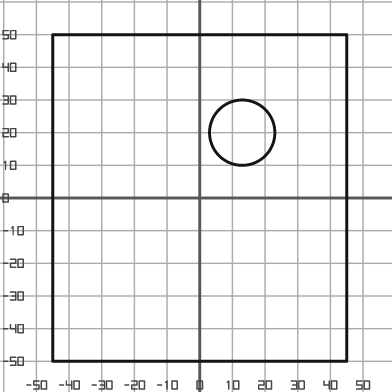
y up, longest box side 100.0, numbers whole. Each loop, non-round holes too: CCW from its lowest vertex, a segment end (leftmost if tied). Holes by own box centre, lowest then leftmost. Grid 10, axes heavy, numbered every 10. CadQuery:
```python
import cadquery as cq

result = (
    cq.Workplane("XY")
    .moveTo(-45.0, -50.0)
    .lineTo(45.0, -50.0)
    .lineTo(45.0, 50.0)
    .lineTo(-45.0, 50.0)
    .close()
    .moveTo(13.0, 20.0)
    .circle(10.0)
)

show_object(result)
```